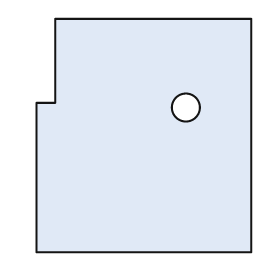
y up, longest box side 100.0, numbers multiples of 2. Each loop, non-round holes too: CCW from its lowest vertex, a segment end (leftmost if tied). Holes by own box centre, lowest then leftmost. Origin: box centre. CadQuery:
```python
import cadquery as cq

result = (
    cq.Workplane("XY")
    .moveTo(-46.0, -50.0)
    .lineTo(46.0, -50.0)
    .lineTo(46.0, 50.0)
    .lineTo(-38.0, 50.0)
    .lineTo(-38.0, 14.0)
    .lineTo(-46.0, 14.0)
    .close()
    .moveTo(18.0, 12.0)
    .circle(6.0)
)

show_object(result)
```